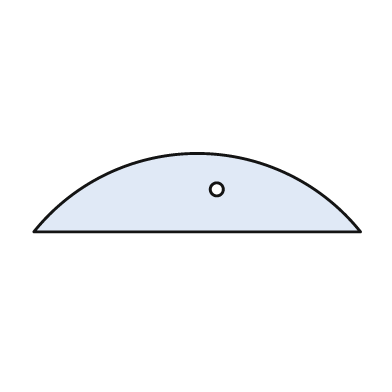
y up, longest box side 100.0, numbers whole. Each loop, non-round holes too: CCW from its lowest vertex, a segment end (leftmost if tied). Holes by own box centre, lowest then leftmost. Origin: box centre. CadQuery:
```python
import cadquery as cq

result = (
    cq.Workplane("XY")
    .moveTo(-50.0, -12.0)
    .lineTo(50.0, -12.0)
    .threePointArc((0.0, 12.0), (-50.0, -12.0))
    .close()
    .moveTo(6.0, 1.0)
    .circle(2.0)
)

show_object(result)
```